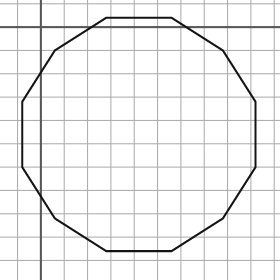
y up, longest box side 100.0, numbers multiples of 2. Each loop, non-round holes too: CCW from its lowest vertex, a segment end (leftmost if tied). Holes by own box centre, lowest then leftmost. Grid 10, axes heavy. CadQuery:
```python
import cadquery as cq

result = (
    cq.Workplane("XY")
    .moveTo(28.0, -96.0)
    .lineTo(56.0, -96.0)
    .lineTo(78.0, -82.0)
    .lineTo(92.0, -60.0)
    .lineTo(92.0, -32.0)
    .lineTo(78.0, -10.0)
    .lineTo(56.0, 4.0)
    .lineTo(28.0, 4.0)
    .lineTo(6.0, -10.0)
    .lineTo(-8.0, -32.0)
    .lineTo(-8.0, -60.0)
    .lineTo(6.0, -82.0)
    .close()
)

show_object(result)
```